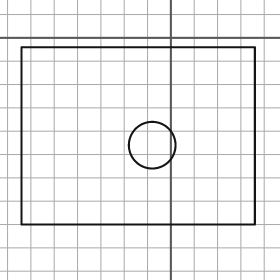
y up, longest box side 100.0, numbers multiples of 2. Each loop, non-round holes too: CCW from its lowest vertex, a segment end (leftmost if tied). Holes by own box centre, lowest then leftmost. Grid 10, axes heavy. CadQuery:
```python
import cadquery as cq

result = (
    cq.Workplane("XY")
    .moveTo(-64.0, -80.0)
    .lineTo(36.0, -80.0)
    .lineTo(36.0, -4.0)
    .lineTo(-64.0, -4.0)
    .close()
    .moveTo(-8.0, -46.0)
    .circle(10.0)
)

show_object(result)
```